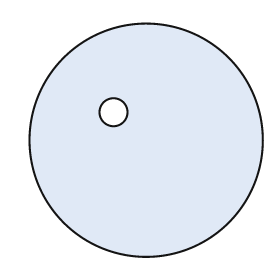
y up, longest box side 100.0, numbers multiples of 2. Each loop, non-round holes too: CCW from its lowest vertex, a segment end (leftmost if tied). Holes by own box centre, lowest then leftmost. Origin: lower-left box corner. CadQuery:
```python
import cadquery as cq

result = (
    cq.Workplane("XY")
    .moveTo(50.0, 50.0)
    .circle(50.0)
    .moveTo(36.0, 62.0)
    .circle(6.0)
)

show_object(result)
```